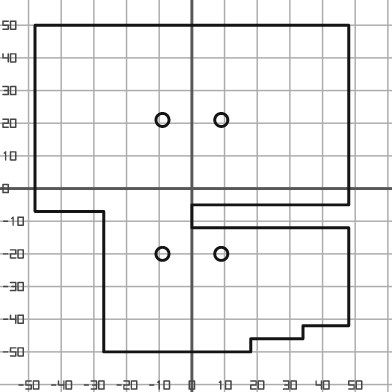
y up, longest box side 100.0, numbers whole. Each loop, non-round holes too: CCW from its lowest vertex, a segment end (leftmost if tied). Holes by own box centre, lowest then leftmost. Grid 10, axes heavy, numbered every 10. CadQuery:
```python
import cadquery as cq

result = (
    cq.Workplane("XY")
    .moveTo(-27.0, -50.0)
    .lineTo(18.0, -50.0)
    .lineTo(18.0, -46.0)
    .lineTo(34.0, -46.0)
    .lineTo(34.0, -42.0)
    .lineTo(48.0, -42.0)
    .lineTo(48.0, -12.0)
    .lineTo(0.0, -12.0)
    .lineTo(0.0, -5.0)
    .lineTo(48.0, -5.0)
    .lineTo(48.0, 50.0)
    .lineTo(-48.0, 50.0)
    .lineTo(-48.0, -7.0)
    .lineTo(-27.0, -7.0)
    .close()
    .moveTo(-9.0, -20.0)
    .circle(2.0)
    .moveTo(9.0, -20.0)
    .circle(2.0)
    .moveTo(-9.0, 21.0)
    .circle(2.0)
    .moveTo(9.0, 21.0)
    .circle(2.0)
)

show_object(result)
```